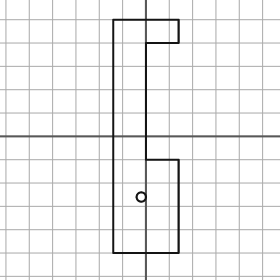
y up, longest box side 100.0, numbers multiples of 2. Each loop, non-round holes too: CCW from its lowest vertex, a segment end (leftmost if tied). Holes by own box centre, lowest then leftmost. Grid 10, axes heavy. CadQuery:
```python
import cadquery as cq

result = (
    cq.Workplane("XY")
    .moveTo(-14.0, -50.0)
    .lineTo(14.0, -50.0)
    .lineTo(14.0, -10.0)
    .lineTo(0.0, -10.0)
    .lineTo(0.0, 40.0)
    .lineTo(14.0, 40.0)
    .lineTo(14.0, 50.0)
    .lineTo(-14.0, 50.0)
    .close()
    .moveTo(-2.0, -26.0)
    .circle(2.0)
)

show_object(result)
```